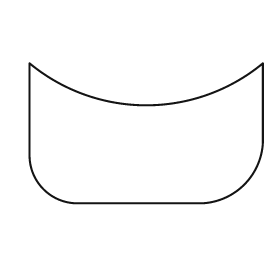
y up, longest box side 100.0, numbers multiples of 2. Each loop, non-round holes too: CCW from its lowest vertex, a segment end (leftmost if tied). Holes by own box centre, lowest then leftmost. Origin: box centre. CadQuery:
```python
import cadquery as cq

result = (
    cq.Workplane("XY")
    .moveTo(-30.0, -30.0)
    .lineTo(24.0, -30.0)
    .threePointArc((42.0, -22.0), (50.0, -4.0))
    .lineTo(50.0, 30.0)
    .threePointArc((0.0, 12.0), (-50.0, 30.0))
    .lineTo(-50.0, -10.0)
    .threePointArc((-44.0, -24.0), (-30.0, -30.0))
    .close()
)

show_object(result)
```